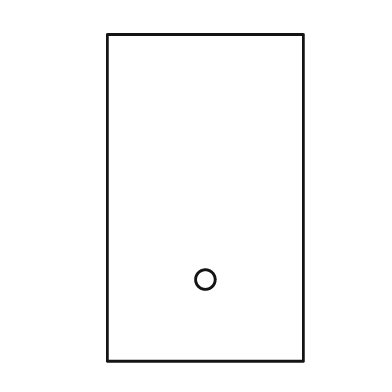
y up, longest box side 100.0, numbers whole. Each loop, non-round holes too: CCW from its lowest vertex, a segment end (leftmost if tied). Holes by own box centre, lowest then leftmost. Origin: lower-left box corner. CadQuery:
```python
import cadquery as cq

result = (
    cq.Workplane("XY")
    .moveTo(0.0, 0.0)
    .lineTo(60.0, 0.0)
    .lineTo(60.0, 100.0)
    .lineTo(0.0, 100.0)
    .close()
    .moveTo(30.0, 25.0)
    .circle(3.0)
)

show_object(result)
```